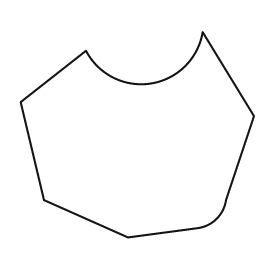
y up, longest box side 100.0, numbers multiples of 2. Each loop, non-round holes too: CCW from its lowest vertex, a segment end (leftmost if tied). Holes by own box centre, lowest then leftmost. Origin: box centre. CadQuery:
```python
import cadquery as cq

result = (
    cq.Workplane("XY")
    .moveTo(-4.0, -44.0)
    .lineTo(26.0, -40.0)
    .threePointArc((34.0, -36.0), (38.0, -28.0))
    .lineTo(50.0, 8.0)
    .lineTo(28.0, 44.0)
    .threePointArc((6.0, 22.0), (-22.0, 36.0))
    .lineTo(-50.0, 14.0)
    .lineTo(-40.0, -28.0)
    .close()
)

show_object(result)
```